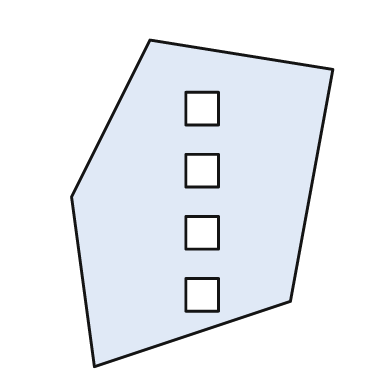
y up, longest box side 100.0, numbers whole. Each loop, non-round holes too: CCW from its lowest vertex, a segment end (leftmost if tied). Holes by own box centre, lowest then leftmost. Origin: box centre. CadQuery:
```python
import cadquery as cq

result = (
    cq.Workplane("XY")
    .moveTo(-33.0, -50.0)
    .lineTo(27.0, -30.0)
    .lineTo(40.0, 41.0)
    .lineTo(-16.0, 50.0)
    .lineTo(-40.0, 2.0)
    .close()
    .moveTo(-5.0, -33.0)
    .lineTo(5.0, -33.0)
    .lineTo(5.0, -23.0)
    .lineTo(-5.0, -23.0)
    .close()
    .moveTo(-5.0, -14.0)
    .lineTo(5.0, -14.0)
    .lineTo(5.0, -4.0)
    .lineTo(-5.0, -4.0)
    .close()
    .moveTo(-5.0, 5.0)
    .lineTo(5.0, 5.0)
    .lineTo(5.0, 15.0)
    .lineTo(-5.0, 15.0)
    .close()
    .moveTo(-5.0, 24.0)
    .lineTo(5.0, 24.0)
    .lineTo(5.0, 34.0)
    .lineTo(-5.0, 34.0)
    .close()
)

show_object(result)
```